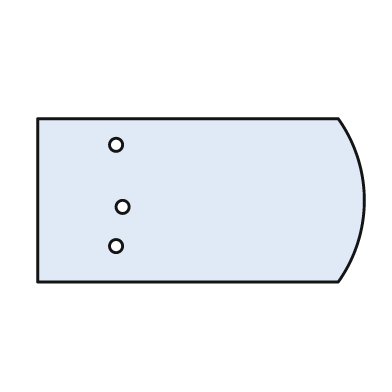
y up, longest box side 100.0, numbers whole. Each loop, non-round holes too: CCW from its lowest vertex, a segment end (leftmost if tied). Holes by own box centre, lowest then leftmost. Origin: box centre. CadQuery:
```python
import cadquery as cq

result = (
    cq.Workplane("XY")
    .moveTo(-50.0, -25.0)
    .lineTo(42.0, -25.0)
    .threePointArc((50.0, 0.0), (42.0, 25.0))
    .lineTo(-50.0, 25.0)
    .close()
    .moveTo(-26.0, -14.0)
    .circle(2.0)
    .moveTo(-24.0, -2.0)
    .circle(2.0)
    .moveTo(-26.0, 17.0)
    .circle(2.0)
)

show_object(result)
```